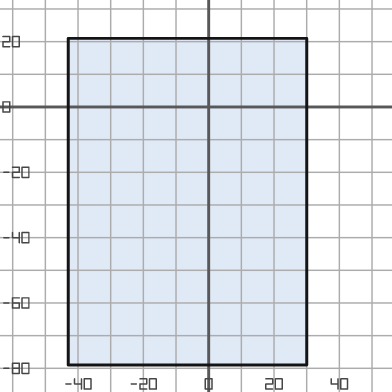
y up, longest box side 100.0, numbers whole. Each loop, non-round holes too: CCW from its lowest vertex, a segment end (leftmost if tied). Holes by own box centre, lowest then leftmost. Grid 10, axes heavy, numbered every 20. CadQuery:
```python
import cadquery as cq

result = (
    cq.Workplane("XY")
    .moveTo(-43.0, -79.0)
    .lineTo(30.0, -79.0)
    .lineTo(30.0, 21.0)
    .lineTo(-43.0, 21.0)
    .close()
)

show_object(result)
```